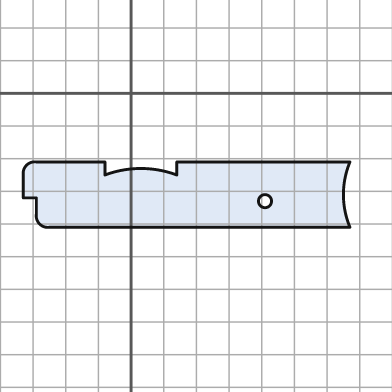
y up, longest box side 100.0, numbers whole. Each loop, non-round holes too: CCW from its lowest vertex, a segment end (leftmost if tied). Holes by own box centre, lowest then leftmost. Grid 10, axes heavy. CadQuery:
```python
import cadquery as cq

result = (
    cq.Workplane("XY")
    .moveTo(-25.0, -41.0)
    .lineTo(67.0, -41.0)
    .threePointArc((65.0, -31.0), (67.0, -21.0))
    .lineTo(14.0, -21.0)
    .lineTo(14.0, -25.0)
    .threePointArc((3.0, -23.0), (-8.0, -25.0))
    .lineTo(-8.0, -21.0)
    .lineTo(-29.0, -21.0)
    .threePointArc((-32.0, -22.0), (-33.0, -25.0))
    .lineTo(-33.0, -32.0)
    .lineTo(-29.0, -32.0)
    .lineTo(-29.0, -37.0)
    .threePointArc((-28.0, -40.0), (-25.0, -41.0))
    .close()
    .moveTo(41.0, -33.0)
    .circle(2.0)
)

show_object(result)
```